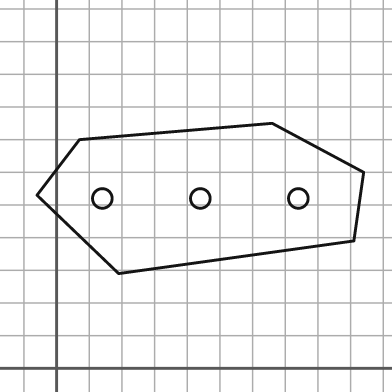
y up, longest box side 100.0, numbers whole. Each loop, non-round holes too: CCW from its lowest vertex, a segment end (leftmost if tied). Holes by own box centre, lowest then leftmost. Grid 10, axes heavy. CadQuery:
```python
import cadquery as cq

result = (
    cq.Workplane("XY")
    .moveTo(19.0, 29.0)
    .lineTo(91.0, 39.0)
    .lineTo(94.0, 60.0)
    .lineTo(66.0, 75.0)
    .lineTo(7.0, 70.0)
    .lineTo(-6.0, 53.0)
    .close()
    .moveTo(14.0, 52.0)
    .circle(3.0)
    .moveTo(44.0, 52.0)
    .circle(3.0)
    .moveTo(74.0, 52.0)
    .circle(3.0)
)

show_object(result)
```